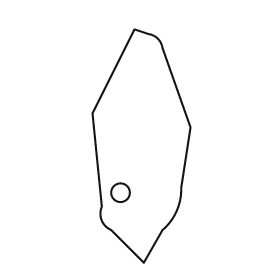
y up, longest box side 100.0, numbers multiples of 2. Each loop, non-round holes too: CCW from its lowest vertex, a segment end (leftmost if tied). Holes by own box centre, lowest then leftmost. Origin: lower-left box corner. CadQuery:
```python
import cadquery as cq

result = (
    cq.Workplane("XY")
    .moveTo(22.0, 0.0)
    .lineTo(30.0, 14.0)
    .threePointArc((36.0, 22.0), (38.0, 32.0))
    .lineTo(42.0, 58.0)
    .lineTo(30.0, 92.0)
    .threePointArc((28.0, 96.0), (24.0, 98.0))
    .lineTo(18.0, 100.0)
    .lineTo(0.0, 64.0)
    .lineTo(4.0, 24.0)
    .threePointArc((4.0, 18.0), (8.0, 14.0))
    .close()
    .moveTo(12.0, 30.0)
    .circle(4.0)
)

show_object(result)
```